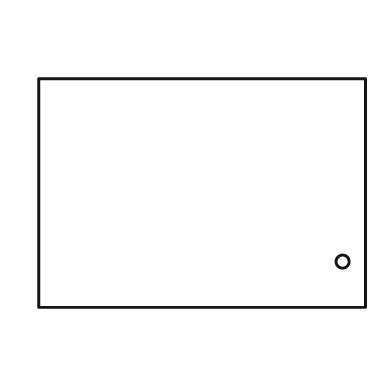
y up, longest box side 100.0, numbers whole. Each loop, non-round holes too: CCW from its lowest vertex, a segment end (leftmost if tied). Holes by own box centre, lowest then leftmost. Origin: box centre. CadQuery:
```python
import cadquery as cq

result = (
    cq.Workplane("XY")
    .moveTo(-50.0, -35.0)
    .lineTo(50.0, -35.0)
    .lineTo(50.0, 35.0)
    .lineTo(-50.0, 35.0)
    .close()
    .moveTo(43.0, -21.0)
    .circle(2.0)
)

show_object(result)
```